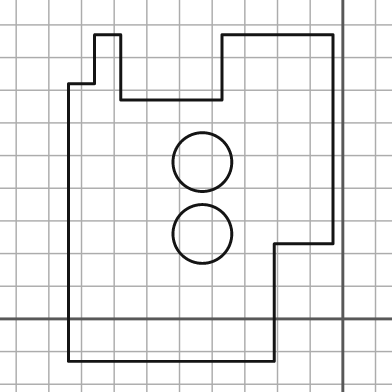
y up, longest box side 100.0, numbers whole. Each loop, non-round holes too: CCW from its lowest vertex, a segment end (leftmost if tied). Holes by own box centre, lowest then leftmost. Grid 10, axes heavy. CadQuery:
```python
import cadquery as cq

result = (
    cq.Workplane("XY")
    .moveTo(-84.0, -13.0)
    .lineTo(-21.0, -13.0)
    .lineTo(-21.0, 23.0)
    .lineTo(-3.0, 23.0)
    .lineTo(-3.0, 87.0)
    .lineTo(-37.0, 87.0)
    .lineTo(-37.0, 67.0)
    .lineTo(-68.0, 67.0)
    .lineTo(-68.0, 87.0)
    .lineTo(-76.0, 87.0)
    .lineTo(-76.0, 72.0)
    .lineTo(-84.0, 72.0)
    .close()
    .moveTo(-43.0, 26.0)
    .circle(9.0)
    .moveTo(-43.0, 48.0)
    .circle(9.0)
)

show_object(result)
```